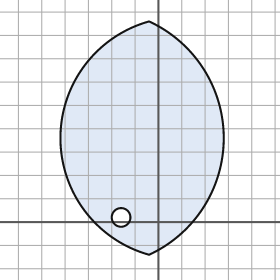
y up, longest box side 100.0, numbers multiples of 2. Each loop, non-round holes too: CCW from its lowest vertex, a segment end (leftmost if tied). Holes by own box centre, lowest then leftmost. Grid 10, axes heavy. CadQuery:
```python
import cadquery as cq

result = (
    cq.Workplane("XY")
    .moveTo(-4.0, -14.0)
    .threePointArc((28.0, 36.0), (-4.0, 86.0))
    .threePointArc((-42.0, 36.0), (-4.0, -14.0))
    .close()
    .moveTo(-16.0, 2.0)
    .circle(4.0)
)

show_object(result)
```